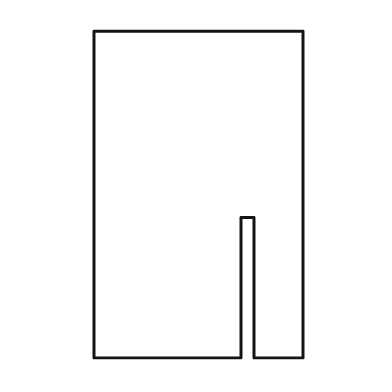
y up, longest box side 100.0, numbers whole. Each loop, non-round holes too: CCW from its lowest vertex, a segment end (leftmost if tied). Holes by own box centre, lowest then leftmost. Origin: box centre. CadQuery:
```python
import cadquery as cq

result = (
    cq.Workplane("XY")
    .moveTo(-32.0, -50.0)
    .lineTo(13.0, -50.0)
    .lineTo(13.0, -7.0)
    .lineTo(17.0, -7.0)
    .lineTo(17.0, -50.0)
    .lineTo(32.0, -50.0)
    .lineTo(32.0, 50.0)
    .lineTo(-32.0, 50.0)
    .close()
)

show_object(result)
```